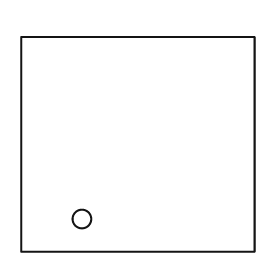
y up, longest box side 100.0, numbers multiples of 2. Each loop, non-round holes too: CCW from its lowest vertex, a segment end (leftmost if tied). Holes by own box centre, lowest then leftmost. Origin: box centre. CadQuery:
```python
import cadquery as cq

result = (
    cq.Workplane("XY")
    .moveTo(-50.0, -46.0)
    .lineTo(50.0, -46.0)
    .lineTo(50.0, 46.0)
    .lineTo(-50.0, 46.0)
    .close()
    .moveTo(-24.0, -32.0)
    .circle(4.0)
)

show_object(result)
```